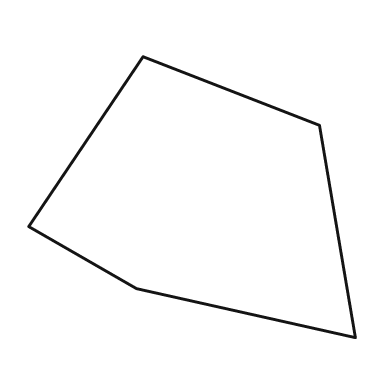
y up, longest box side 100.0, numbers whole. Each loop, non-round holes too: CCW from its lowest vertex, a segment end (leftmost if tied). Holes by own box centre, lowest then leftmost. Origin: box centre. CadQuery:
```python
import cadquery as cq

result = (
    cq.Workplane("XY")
    .moveTo(50.0, -43.0)
    .lineTo(39.0, 22.0)
    .lineTo(-15.0, 43.0)
    .lineTo(-50.0, -9.0)
    .lineTo(-17.0, -28.0)
    .close()
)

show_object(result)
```